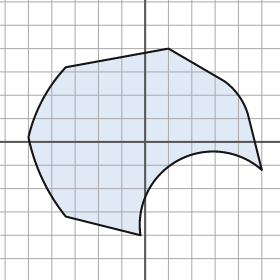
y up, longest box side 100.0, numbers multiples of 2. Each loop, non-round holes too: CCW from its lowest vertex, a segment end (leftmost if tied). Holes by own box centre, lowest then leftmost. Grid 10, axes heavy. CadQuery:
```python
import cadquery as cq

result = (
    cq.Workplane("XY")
    .moveTo(-2.0, -40.0)
    .threePointArc((14.0, -8.0), (50.0, -12.0))
    .lineTo(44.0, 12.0)
    .threePointArc((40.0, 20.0), (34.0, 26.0))
    .lineTo(10.0, 40.0)
    .lineTo(-34.0, 32.0)
    .threePointArc((-44.0, 18.0), (-50.0, 2.0))
    .threePointArc((-44.0, -16.0), (-34.0, -32.0))
    .close()
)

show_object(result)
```